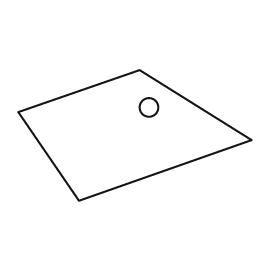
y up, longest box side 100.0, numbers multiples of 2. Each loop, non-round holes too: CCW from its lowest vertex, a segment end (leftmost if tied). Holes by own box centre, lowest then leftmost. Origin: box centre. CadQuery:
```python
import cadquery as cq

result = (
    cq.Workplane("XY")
    .moveTo(-24.0, -28.0)
    .lineTo(50.0, -2.0)
    .lineTo(2.0, 28.0)
    .lineTo(-50.0, 10.0)
    .close()
    .moveTo(6.0, 12.0)
    .circle(4.0)
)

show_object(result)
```